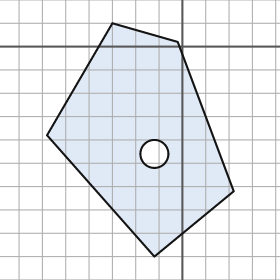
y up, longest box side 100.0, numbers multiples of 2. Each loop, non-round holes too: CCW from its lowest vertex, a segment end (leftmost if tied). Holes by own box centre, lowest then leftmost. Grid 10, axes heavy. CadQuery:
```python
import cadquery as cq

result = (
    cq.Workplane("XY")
    .moveTo(-12.0, -90.0)
    .lineTo(22.0, -62.0)
    .lineTo(-2.0, 2.0)
    .lineTo(-30.0, 10.0)
    .lineTo(-58.0, -38.0)
    .close()
    .moveTo(-12.0, -46.0)
    .circle(6.0)
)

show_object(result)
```